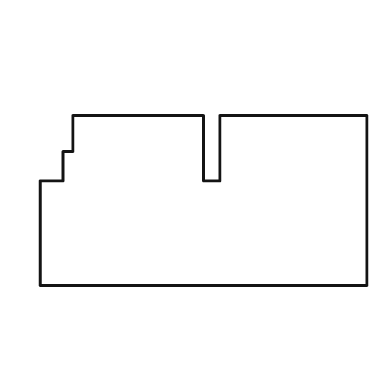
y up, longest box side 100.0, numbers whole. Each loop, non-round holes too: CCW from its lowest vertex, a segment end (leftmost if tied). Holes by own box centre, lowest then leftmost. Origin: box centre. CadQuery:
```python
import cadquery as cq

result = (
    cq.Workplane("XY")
    .moveTo(-50.0, -26.0)
    .lineTo(50.0, -26.0)
    .lineTo(50.0, 26.0)
    .lineTo(5.0, 26.0)
    .lineTo(5.0, 6.0)
    .lineTo(0.0, 6.0)
    .lineTo(0.0, 26.0)
    .lineTo(-40.0, 26.0)
    .lineTo(-40.0, 15.0)
    .lineTo(-43.0, 15.0)
    .lineTo(-43.0, 6.0)
    .lineTo(-50.0, 6.0)
    .close()
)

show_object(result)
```